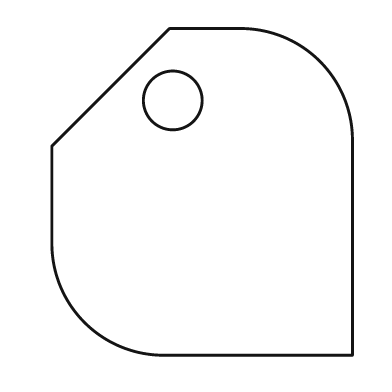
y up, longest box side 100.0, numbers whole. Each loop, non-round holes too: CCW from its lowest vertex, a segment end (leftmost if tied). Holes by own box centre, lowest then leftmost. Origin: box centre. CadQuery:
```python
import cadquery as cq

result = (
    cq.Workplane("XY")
    .moveTo(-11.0, -50.0)
    .lineTo(46.0, -50.0)
    .lineTo(46.0, 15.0)
    .threePointArc((36.0, 40.0), (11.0, 50.0))
    .lineTo(-10.0, 50.0)
    .lineTo(-46.0, 14.0)
    .lineTo(-46.0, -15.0)
    .threePointArc((-36.0, -40.0), (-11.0, -50.0))
    .close()
    .moveTo(-9.0, 28.0)
    .circle(9.0)
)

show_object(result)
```